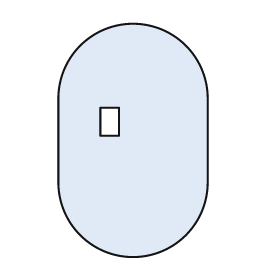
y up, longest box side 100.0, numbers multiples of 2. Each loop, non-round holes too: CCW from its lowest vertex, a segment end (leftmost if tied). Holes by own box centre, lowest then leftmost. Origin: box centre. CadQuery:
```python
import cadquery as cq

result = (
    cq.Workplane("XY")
    .moveTo(-32.0, -18.0)
    .threePointArc((0.0, -50.0), (32.0, -18.0))
    .lineTo(32.0, 18.0)
    .threePointArc((0.0, 50.0), (-32.0, 18.0))
    .close()
    .moveTo(-14.0, 2.0)
    .lineTo(-6.0, 2.0)
    .lineTo(-6.0, 14.0)
    .lineTo(-14.0, 14.0)
    .close()
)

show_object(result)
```